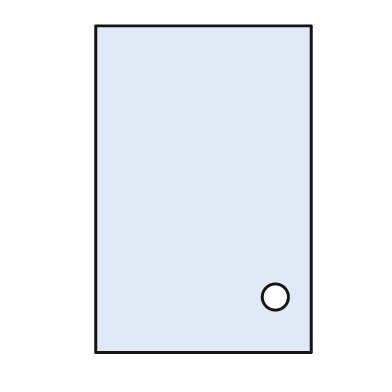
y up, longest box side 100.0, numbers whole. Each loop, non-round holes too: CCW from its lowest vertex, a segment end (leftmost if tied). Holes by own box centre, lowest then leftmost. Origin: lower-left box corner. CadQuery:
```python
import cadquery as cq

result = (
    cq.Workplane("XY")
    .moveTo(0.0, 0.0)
    .lineTo(66.0, 0.0)
    .lineTo(66.0, 100.0)
    .lineTo(0.0, 100.0)
    .close()
    .moveTo(55.0, 17.0)
    .circle(4.0)
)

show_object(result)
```